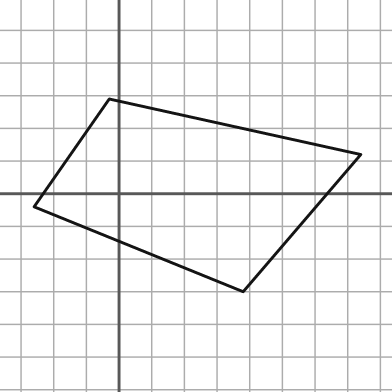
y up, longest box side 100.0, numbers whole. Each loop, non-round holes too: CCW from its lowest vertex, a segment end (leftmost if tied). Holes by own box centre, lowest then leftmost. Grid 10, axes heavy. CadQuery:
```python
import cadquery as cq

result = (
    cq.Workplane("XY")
    .moveTo(38.0, -30.0)
    .lineTo(74.0, 12.0)
    .lineTo(-3.0, 29.0)
    .lineTo(-26.0, -4.0)
    .close()
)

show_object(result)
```